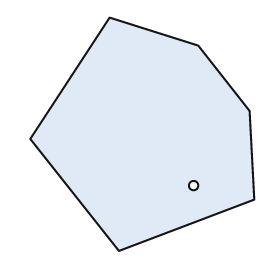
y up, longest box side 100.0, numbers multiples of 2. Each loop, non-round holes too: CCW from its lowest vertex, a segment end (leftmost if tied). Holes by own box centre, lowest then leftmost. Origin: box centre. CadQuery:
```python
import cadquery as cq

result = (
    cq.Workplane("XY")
    .moveTo(-10.0, -50.0)
    .lineTo(48.0, -28.0)
    .lineTo(46.0, 10.0)
    .lineTo(24.0, 38.0)
    .lineTo(-14.0, 50.0)
    .lineTo(-48.0, -2.0)
    .close()
    .moveTo(22.0, -22.0)
    .circle(2.0)
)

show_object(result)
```